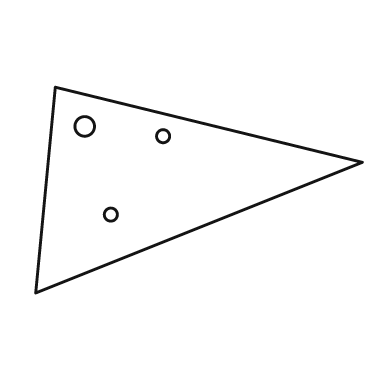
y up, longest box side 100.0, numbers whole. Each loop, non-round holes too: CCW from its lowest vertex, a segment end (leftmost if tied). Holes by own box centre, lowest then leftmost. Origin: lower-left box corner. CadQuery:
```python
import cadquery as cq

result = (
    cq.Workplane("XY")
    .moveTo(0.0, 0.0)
    .lineTo(100.0, 40.0)
    .lineTo(6.0, 63.0)
    .close()
    .moveTo(23.0, 24.0)
    .circle(2.0)
    .moveTo(39.0, 48.0)
    .circle(2.0)
    .moveTo(15.0, 51.0)
    .circle(3.0)
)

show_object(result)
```